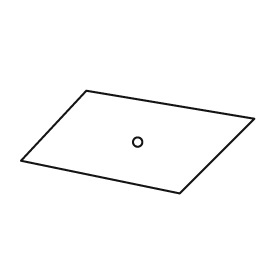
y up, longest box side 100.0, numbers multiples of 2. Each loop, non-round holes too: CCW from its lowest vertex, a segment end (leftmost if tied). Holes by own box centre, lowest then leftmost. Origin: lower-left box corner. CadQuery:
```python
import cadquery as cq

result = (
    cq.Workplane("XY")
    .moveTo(68.0, 0.0)
    .lineTo(100.0, 32.0)
    .lineTo(28.0, 44.0)
    .lineTo(0.0, 14.0)
    .close()
    .moveTo(50.0, 22.0)
    .circle(2.0)
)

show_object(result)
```